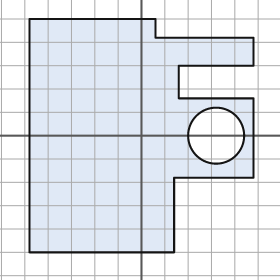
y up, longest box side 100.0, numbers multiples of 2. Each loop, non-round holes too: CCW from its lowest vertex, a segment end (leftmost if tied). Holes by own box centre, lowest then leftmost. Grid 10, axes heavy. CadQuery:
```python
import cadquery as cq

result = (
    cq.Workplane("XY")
    .moveTo(-48.0, -50.0)
    .lineTo(14.0, -50.0)
    .lineTo(14.0, -18.0)
    .lineTo(48.0, -18.0)
    .lineTo(48.0, 16.0)
    .lineTo(16.0, 16.0)
    .lineTo(16.0, 30.0)
    .lineTo(48.0, 30.0)
    .lineTo(48.0, 42.0)
    .lineTo(6.0, 42.0)
    .lineTo(6.0, 50.0)
    .lineTo(-48.0, 50.0)
    .close()
    .moveTo(32.0, 0.0)
    .circle(12.0)
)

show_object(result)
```